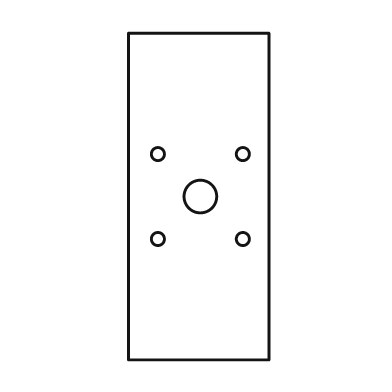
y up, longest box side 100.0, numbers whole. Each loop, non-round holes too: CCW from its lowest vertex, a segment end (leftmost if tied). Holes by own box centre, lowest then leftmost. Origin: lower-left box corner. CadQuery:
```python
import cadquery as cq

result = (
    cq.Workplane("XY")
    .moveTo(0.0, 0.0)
    .lineTo(43.0, 0.0)
    .lineTo(43.0, 100.0)
    .lineTo(0.0, 100.0)
    .close()
    .moveTo(9.0, 37.0)
    .circle(2.0)
    .moveTo(35.0, 37.0)
    .circle(2.0)
    .moveTo(22.0, 50.0)
    .circle(5.0)
    .moveTo(9.0, 63.0)
    .circle(2.0)
    .moveTo(35.0, 63.0)
    .circle(2.0)
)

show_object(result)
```